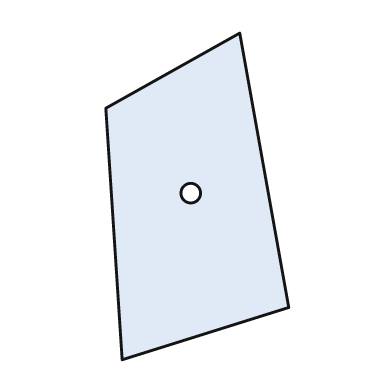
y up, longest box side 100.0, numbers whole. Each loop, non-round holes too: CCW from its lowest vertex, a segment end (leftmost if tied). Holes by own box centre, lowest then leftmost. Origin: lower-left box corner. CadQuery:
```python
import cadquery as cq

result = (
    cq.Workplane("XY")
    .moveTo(5.0, 0.0)
    .lineTo(56.0, 16.0)
    .lineTo(41.0, 100.0)
    .lineTo(0.0, 77.0)
    .close()
    .moveTo(26.0, 51.0)
    .circle(3.0)
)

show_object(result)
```